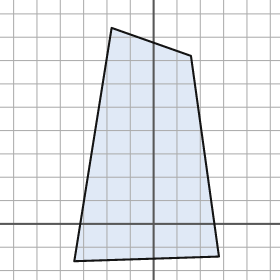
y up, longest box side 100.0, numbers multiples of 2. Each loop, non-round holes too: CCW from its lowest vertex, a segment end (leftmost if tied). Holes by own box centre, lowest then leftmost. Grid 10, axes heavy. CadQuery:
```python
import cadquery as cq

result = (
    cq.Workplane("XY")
    .moveTo(-34.0, -16.0)
    .lineTo(28.0, -14.0)
    .lineTo(16.0, 72.0)
    .lineTo(-18.0, 84.0)
    .close()
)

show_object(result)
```